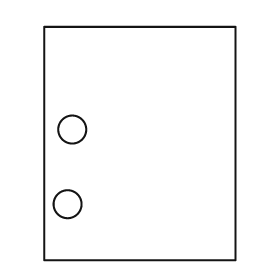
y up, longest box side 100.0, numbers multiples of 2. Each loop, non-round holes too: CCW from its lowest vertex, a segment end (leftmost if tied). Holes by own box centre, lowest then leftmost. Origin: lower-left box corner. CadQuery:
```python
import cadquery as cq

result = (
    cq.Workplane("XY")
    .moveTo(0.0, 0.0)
    .lineTo(82.0, 0.0)
    .lineTo(82.0, 100.0)
    .lineTo(0.0, 100.0)
    .close()
    .moveTo(10.0, 24.0)
    .circle(6.0)
    .moveTo(12.0, 56.0)
    .circle(6.0)
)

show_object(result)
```